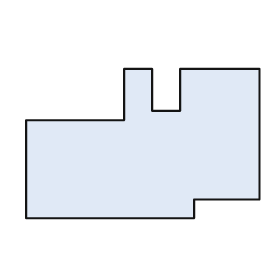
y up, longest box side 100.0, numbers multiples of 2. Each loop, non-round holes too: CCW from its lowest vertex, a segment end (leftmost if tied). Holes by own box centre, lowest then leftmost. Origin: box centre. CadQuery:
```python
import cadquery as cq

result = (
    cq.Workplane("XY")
    .moveTo(-50.0, -32.0)
    .lineTo(22.0, -32.0)
    .lineTo(22.0, -24.0)
    .lineTo(50.0, -24.0)
    .lineTo(50.0, 32.0)
    .lineTo(16.0, 32.0)
    .lineTo(16.0, 14.0)
    .lineTo(4.0, 14.0)
    .lineTo(4.0, 32.0)
    .lineTo(-8.0, 32.0)
    .lineTo(-8.0, 10.0)
    .lineTo(-50.0, 10.0)
    .close()
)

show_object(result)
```